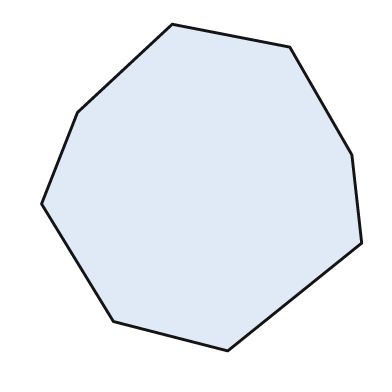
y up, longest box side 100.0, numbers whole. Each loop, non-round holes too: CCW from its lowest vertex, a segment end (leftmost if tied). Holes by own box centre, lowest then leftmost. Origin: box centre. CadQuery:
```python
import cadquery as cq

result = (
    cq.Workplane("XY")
    .moveTo(8.0, -50.0)
    .lineTo(49.0, -17.0)
    .lineTo(46.0, 10.0)
    .lineTo(27.0, 43.0)
    .lineTo(-9.0, 50.0)
    .lineTo(-38.0, 23.0)
    .lineTo(-49.0, -5.0)
    .lineTo(-27.0, -41.0)
    .close()
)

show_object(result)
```